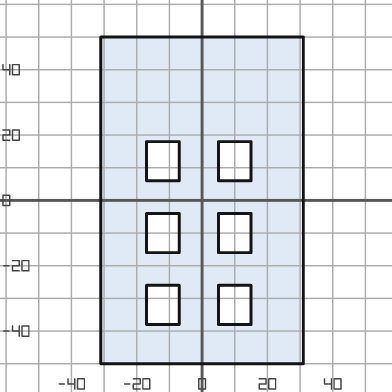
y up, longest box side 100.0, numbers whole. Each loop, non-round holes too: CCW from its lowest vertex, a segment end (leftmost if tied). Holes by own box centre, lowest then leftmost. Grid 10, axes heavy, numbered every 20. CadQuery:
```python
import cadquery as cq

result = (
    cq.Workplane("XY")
    .moveTo(-31.0, -50.0)
    .lineTo(31.0, -50.0)
    .lineTo(31.0, 50.0)
    .lineTo(-31.0, 50.0)
    .close()
    .moveTo(-17.0, -38.0)
    .lineTo(-7.0, -38.0)
    .lineTo(-7.0, -26.0)
    .lineTo(-17.0, -26.0)
    .close()
    .moveTo(5.0, -38.0)
    .lineTo(15.0, -38.0)
    .lineTo(15.0, -26.0)
    .lineTo(5.0, -26.0)
    .close()
    .moveTo(-17.0, -16.0)
    .lineTo(-7.0, -16.0)
    .lineTo(-7.0, -4.0)
    .lineTo(-17.0, -4.0)
    .close()
    .moveTo(5.0, -16.0)
    .lineTo(15.0, -16.0)
    .lineTo(15.0, -4.0)
    .lineTo(5.0, -4.0)
    .close()
    .moveTo(-17.0, 6.0)
    .lineTo(-7.0, 6.0)
    .lineTo(-7.0, 18.0)
    .lineTo(-17.0, 18.0)
    .close()
    .moveTo(5.0, 6.0)
    .lineTo(15.0, 6.0)
    .lineTo(15.0, 18.0)
    .lineTo(5.0, 18.0)
    .close()
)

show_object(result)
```